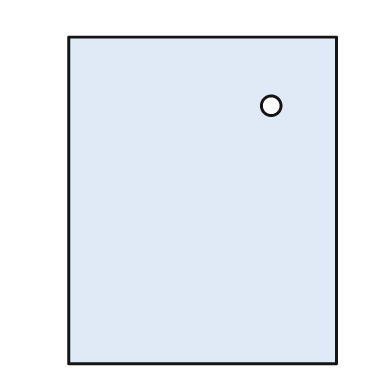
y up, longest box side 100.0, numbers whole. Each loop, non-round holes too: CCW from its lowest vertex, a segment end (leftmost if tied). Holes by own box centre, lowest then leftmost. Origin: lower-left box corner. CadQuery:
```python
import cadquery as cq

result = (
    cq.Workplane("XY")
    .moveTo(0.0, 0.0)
    .lineTo(82.0, 0.0)
    .lineTo(82.0, 100.0)
    .lineTo(0.0, 100.0)
    .close()
    .moveTo(62.0, 79.0)
    .circle(3.0)
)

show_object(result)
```